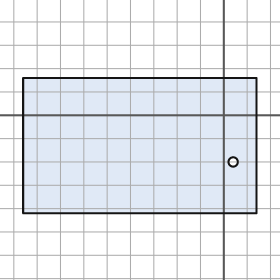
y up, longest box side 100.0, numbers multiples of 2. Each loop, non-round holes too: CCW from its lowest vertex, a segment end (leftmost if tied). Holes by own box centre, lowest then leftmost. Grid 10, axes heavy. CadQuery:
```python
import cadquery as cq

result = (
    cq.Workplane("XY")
    .moveTo(-86.0, -42.0)
    .lineTo(14.0, -42.0)
    .lineTo(14.0, 16.0)
    .lineTo(-86.0, 16.0)
    .close()
    .moveTo(4.0, -20.0)
    .circle(2.0)
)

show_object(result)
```